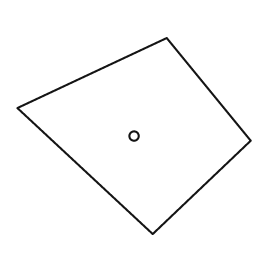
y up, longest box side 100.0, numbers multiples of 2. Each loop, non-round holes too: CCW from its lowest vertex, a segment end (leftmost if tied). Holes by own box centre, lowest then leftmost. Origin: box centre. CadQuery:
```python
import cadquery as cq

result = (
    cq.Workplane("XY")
    .moveTo(8.0, -42.0)
    .lineTo(50.0, -2.0)
    .lineTo(14.0, 42.0)
    .lineTo(-50.0, 12.0)
    .close()
    .moveTo(0.0, 0.0)
    .circle(2.0)
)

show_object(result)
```